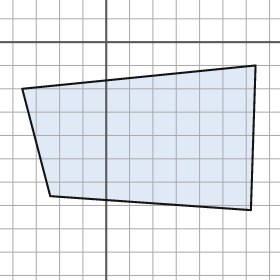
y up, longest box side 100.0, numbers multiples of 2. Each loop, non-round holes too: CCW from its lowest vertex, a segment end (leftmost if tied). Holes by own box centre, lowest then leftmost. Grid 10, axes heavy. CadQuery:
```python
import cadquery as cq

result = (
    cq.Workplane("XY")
    .moveTo(62.0, -72.0)
    .lineTo(64.0, -10.0)
    .lineTo(-36.0, -20.0)
    .lineTo(-24.0, -66.0)
    .close()
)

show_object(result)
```